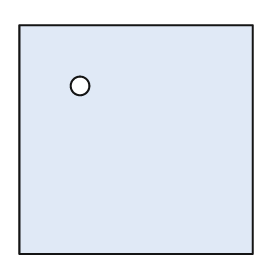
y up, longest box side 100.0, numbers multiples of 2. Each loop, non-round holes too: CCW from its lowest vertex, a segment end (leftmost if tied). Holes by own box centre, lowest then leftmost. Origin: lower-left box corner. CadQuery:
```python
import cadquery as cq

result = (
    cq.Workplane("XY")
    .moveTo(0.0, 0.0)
    .lineTo(100.0, 0.0)
    .lineTo(100.0, 98.0)
    .lineTo(0.0, 98.0)
    .close()
    .moveTo(26.0, 72.0)
    .circle(4.0)
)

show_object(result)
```